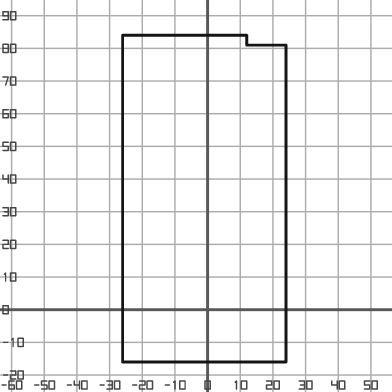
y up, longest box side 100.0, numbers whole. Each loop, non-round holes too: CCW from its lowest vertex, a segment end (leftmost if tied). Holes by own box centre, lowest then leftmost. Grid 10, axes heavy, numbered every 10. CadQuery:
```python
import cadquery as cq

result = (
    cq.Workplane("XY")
    .moveTo(-26.0, -16.0)
    .lineTo(24.0, -16.0)
    .lineTo(24.0, 81.0)
    .lineTo(12.0, 81.0)
    .lineTo(12.0, 84.0)
    .lineTo(-26.0, 84.0)
    .close()
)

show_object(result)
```